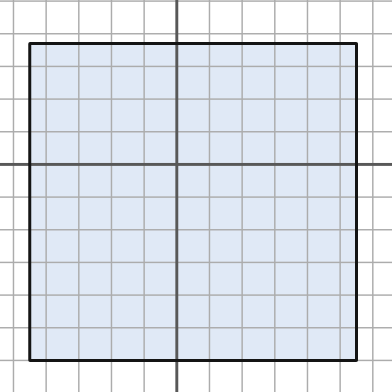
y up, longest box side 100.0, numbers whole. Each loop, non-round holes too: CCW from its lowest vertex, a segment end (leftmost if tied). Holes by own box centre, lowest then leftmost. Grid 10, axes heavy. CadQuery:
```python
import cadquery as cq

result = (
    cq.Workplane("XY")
    .moveTo(-45.0, -60.0)
    .lineTo(55.0, -60.0)
    .lineTo(55.0, 37.0)
    .lineTo(-45.0, 37.0)
    .close()
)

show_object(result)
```